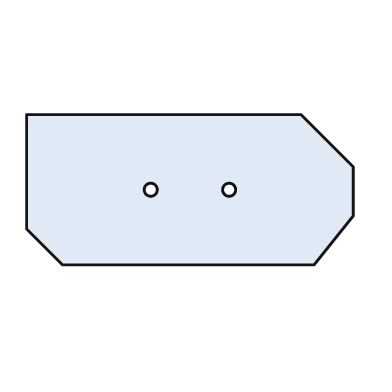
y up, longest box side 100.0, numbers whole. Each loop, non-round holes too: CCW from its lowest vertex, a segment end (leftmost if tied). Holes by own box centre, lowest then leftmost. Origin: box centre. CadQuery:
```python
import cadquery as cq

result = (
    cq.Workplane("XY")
    .moveTo(-39.0, -23.0)
    .lineTo(38.0, -23.0)
    .lineTo(50.0, -8.0)
    .lineTo(50.0, 7.0)
    .lineTo(34.0, 23.0)
    .lineTo(-50.0, 23.0)
    .lineTo(-50.0, -12.0)
    .close()
    .moveTo(-12.0, 0.0)
    .circle(2.0)
    .moveTo(12.0, 0.0)
    .circle(2.0)
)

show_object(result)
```